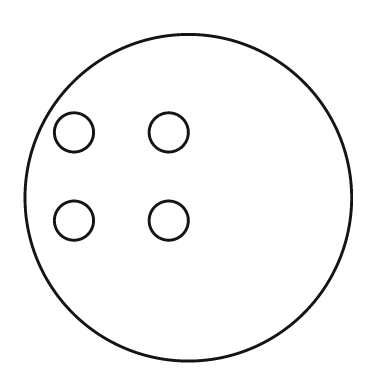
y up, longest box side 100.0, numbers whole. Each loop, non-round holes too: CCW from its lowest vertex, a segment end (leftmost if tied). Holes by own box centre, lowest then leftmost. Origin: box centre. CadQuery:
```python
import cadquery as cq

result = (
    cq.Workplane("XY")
    .moveTo(0.0, 0.0)
    .circle(50.0)
    .moveTo(-35.0, -7.0)
    .circle(6.0)
    .moveTo(-6.0, -7.0)
    .circle(6.0)
    .moveTo(-35.0, 20.0)
    .circle(6.0)
    .moveTo(-6.0, 20.0)
    .circle(6.0)
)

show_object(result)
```